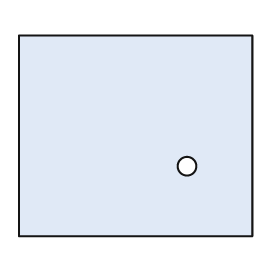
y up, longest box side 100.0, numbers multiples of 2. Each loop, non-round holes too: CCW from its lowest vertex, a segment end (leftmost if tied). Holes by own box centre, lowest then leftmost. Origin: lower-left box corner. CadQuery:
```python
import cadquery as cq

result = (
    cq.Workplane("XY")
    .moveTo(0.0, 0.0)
    .lineTo(100.0, 0.0)
    .lineTo(100.0, 86.0)
    .lineTo(0.0, 86.0)
    .close()
    .moveTo(72.0, 30.0)
    .circle(4.0)
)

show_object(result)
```